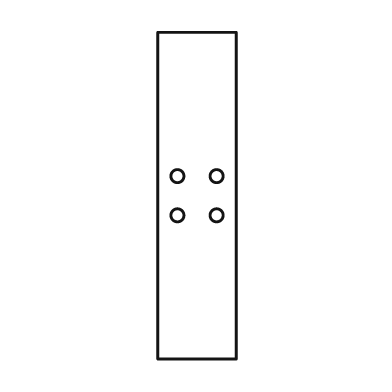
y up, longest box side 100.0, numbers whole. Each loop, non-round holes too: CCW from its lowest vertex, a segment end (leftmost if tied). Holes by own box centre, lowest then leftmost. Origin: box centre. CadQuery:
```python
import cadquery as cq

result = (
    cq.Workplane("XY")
    .moveTo(-12.0, -50.0)
    .lineTo(12.0, -50.0)
    .lineTo(12.0, 50.0)
    .lineTo(-12.0, 50.0)
    .close()
    .moveTo(-6.0, -6.0)
    .circle(2.0)
    .moveTo(6.0, -6.0)
    .circle(2.0)
    .moveTo(-6.0, 6.0)
    .circle(2.0)
    .moveTo(6.0, 6.0)
    .circle(2.0)
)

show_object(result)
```